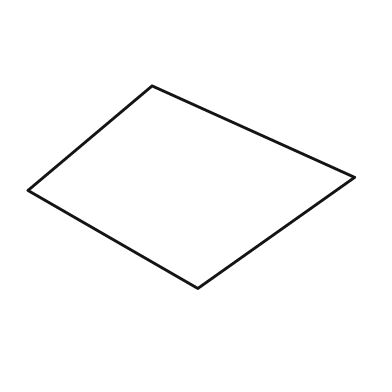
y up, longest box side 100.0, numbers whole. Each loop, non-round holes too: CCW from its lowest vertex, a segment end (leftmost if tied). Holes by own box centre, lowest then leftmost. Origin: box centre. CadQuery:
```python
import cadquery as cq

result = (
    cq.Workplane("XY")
    .moveTo(2.0, -31.0)
    .lineTo(50.0, 3.0)
    .lineTo(-12.0, 31.0)
    .lineTo(-50.0, -1.0)
    .close()
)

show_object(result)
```